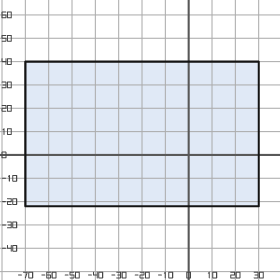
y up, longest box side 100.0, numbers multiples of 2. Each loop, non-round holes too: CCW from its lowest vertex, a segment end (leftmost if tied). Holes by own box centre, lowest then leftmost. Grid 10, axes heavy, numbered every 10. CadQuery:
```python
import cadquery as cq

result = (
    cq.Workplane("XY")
    .moveTo(-70.0, -22.0)
    .lineTo(30.0, -22.0)
    .lineTo(30.0, 40.0)
    .lineTo(-70.0, 40.0)
    .close()
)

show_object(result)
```